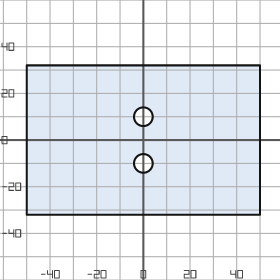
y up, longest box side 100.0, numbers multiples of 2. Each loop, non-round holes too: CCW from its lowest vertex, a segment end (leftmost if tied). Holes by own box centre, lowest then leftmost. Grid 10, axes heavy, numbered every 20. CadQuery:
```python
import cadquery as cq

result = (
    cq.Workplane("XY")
    .moveTo(-50.0, -32.0)
    .lineTo(50.0, -32.0)
    .lineTo(50.0, 32.0)
    .lineTo(-50.0, 32.0)
    .close()
    .moveTo(0.0, -10.0)
    .circle(4.0)
    .moveTo(0.0, 10.0)
    .circle(4.0)
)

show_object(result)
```